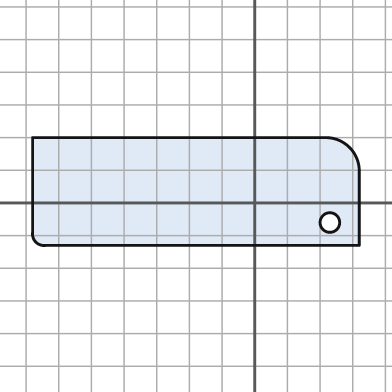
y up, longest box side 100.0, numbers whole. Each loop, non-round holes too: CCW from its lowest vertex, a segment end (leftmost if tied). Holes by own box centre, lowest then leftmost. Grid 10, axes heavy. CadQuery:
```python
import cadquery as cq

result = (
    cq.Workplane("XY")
    .moveTo(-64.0, -13.0)
    .lineTo(32.0, -13.0)
    .lineTo(32.0, 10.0)
    .threePointArc((29.0, 17.0), (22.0, 20.0))
    .lineTo(-68.0, 20.0)
    .lineTo(-68.0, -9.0)
    .threePointArc((-67.0, -12.0), (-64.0, -13.0))
    .close()
    .moveTo(23.0, -6.0)
    .circle(3.0)
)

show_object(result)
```